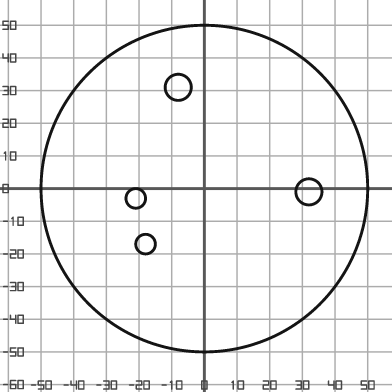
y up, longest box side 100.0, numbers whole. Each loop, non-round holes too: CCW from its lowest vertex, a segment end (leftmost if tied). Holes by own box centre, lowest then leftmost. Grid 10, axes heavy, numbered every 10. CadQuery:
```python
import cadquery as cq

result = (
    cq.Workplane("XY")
    .moveTo(0.0, 0.0)
    .circle(50.0)
    .moveTo(-18.0, -17.0)
    .circle(3.0)
    .moveTo(-21.0, -3.0)
    .circle(3.0)
    .moveTo(32.0, -1.0)
    .circle(4.0)
    .moveTo(-8.0, 31.0)
    .circle(4.0)
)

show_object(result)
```